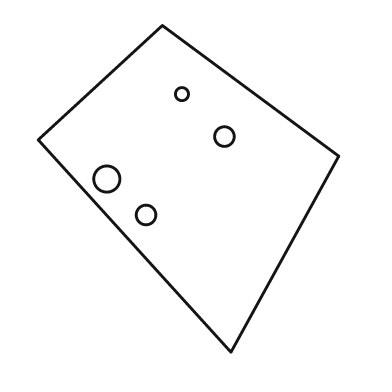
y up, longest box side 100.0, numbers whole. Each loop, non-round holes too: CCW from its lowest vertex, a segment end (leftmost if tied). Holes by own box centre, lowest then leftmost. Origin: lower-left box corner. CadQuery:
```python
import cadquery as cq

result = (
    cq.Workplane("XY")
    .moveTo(59.0, 0.0)
    .lineTo(92.0, 60.0)
    .lineTo(38.0, 100.0)
    .lineTo(0.0, 65.0)
    .close()
    .moveTo(33.0, 42.0)
    .circle(3.0)
    .moveTo(21.0, 53.0)
    .circle(4.0)
    .moveTo(57.0, 66.0)
    .circle(3.0)
    .moveTo(44.0, 79.0)
    .circle(2.0)
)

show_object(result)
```